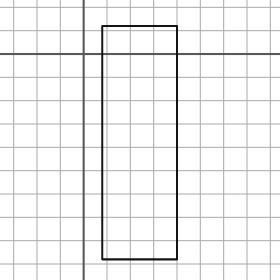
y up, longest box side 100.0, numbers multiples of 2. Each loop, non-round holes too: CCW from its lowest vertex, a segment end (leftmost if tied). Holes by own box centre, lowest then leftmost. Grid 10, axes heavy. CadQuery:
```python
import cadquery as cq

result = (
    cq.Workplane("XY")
    .moveTo(8.0, -88.0)
    .lineTo(40.0, -88.0)
    .lineTo(40.0, 12.0)
    .lineTo(8.0, 12.0)
    .close()
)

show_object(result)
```